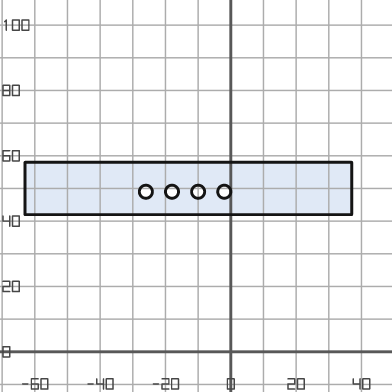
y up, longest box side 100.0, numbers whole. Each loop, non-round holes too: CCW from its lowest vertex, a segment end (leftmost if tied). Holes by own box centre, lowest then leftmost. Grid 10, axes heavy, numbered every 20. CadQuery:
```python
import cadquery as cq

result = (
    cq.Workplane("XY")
    .moveTo(-63.0, 42.0)
    .lineTo(37.0, 42.0)
    .lineTo(37.0, 58.0)
    .lineTo(-63.0, 58.0)
    .close()
    .moveTo(-26.0, 49.0)
    .circle(2.0)
    .moveTo(-18.0, 49.0)
    .circle(2.0)
    .moveTo(-10.0, 49.0)
    .circle(2.0)
    .moveTo(-2.0, 49.0)
    .circle(2.0)
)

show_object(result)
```